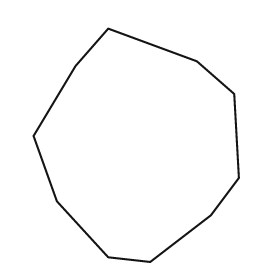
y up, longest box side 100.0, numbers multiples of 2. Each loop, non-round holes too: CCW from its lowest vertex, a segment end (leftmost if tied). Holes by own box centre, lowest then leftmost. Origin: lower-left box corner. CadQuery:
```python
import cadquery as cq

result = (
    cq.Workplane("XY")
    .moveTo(50.0, 0.0)
    .lineTo(76.0, 20.0)
    .lineTo(88.0, 36.0)
    .lineTo(86.0, 72.0)
    .lineTo(70.0, 86.0)
    .lineTo(32.0, 100.0)
    .lineTo(18.0, 84.0)
    .lineTo(0.0, 54.0)
    .lineTo(10.0, 26.0)
    .lineTo(32.0, 2.0)
    .close()
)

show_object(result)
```